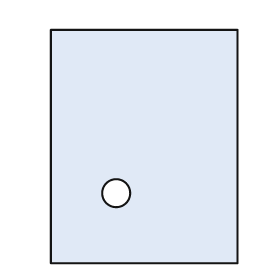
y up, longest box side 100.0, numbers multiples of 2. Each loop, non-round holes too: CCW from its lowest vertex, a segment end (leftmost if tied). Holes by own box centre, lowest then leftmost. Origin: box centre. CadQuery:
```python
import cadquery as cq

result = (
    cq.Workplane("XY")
    .moveTo(-40.0, -50.0)
    .lineTo(40.0, -50.0)
    .lineTo(40.0, 50.0)
    .lineTo(-40.0, 50.0)
    .close()
    .moveTo(-12.0, -20.0)
    .circle(6.0)
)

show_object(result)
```